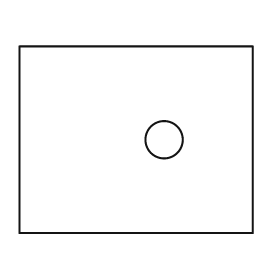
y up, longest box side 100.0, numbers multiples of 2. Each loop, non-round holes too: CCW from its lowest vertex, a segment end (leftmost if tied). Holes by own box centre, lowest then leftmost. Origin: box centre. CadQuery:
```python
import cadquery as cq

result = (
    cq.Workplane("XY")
    .moveTo(-50.0, -40.0)
    .lineTo(50.0, -40.0)
    .lineTo(50.0, 40.0)
    .lineTo(-50.0, 40.0)
    .close()
    .moveTo(12.0, 0.0)
    .circle(8.0)
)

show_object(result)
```